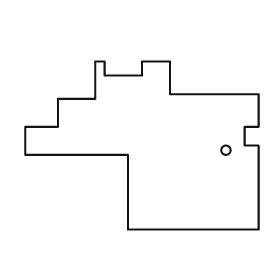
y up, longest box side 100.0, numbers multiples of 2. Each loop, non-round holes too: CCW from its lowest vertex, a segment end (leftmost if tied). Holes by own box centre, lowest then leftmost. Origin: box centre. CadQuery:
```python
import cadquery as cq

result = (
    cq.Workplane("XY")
    .moveTo(-6.0, -36.0)
    .lineTo(50.0, -36.0)
    .lineTo(50.0, 0.0)
    .lineTo(44.0, 0.0)
    .lineTo(44.0, 8.0)
    .lineTo(50.0, 8.0)
    .lineTo(50.0, 22.0)
    .lineTo(12.0, 22.0)
    .lineTo(12.0, 36.0)
    .lineTo(0.0, 36.0)
    .lineTo(0.0, 30.0)
    .lineTo(-16.0, 30.0)
    .lineTo(-16.0, 36.0)
    .lineTo(-20.0, 36.0)
    .lineTo(-20.0, 20.0)
    .lineTo(-36.0, 20.0)
    .lineTo(-36.0, 8.0)
    .lineTo(-50.0, 8.0)
    .lineTo(-50.0, -4.0)
    .lineTo(-6.0, -4.0)
    .close()
    .moveTo(36.0, -2.0)
    .circle(2.0)
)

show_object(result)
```